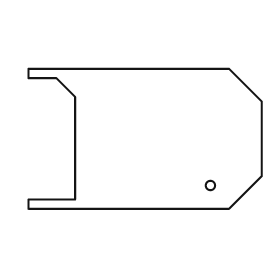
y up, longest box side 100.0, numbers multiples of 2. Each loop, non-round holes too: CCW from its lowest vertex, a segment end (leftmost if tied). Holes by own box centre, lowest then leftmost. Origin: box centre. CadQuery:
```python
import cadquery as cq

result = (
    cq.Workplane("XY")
    .moveTo(-50.0, -30.0)
    .lineTo(36.0, -30.0)
    .lineTo(50.0, -16.0)
    .lineTo(50.0, 16.0)
    .lineTo(36.0, 30.0)
    .lineTo(-50.0, 30.0)
    .lineTo(-50.0, 26.0)
    .lineTo(-38.0, 26.0)
    .lineTo(-30.0, 18.0)
    .lineTo(-30.0, -26.0)
    .lineTo(-50.0, -26.0)
    .close()
    .moveTo(28.0, -20.0)
    .circle(2.0)
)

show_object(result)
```